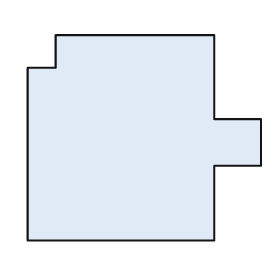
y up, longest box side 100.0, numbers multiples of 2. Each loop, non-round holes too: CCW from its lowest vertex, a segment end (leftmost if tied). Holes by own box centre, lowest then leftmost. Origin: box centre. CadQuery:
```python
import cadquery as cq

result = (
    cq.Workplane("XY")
    .moveTo(-50.0, -44.0)
    .lineTo(30.0, -44.0)
    .lineTo(30.0, -12.0)
    .lineTo(50.0, -12.0)
    .lineTo(50.0, 8.0)
    .lineTo(30.0, 8.0)
    .lineTo(30.0, 44.0)
    .lineTo(-38.0, 44.0)
    .lineTo(-38.0, 30.0)
    .lineTo(-50.0, 30.0)
    .close()
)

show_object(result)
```